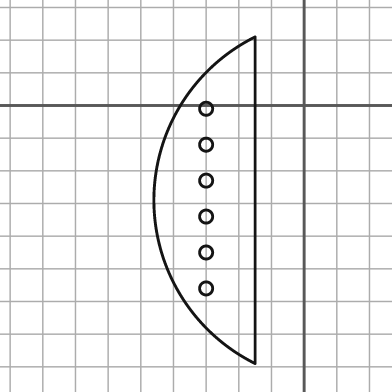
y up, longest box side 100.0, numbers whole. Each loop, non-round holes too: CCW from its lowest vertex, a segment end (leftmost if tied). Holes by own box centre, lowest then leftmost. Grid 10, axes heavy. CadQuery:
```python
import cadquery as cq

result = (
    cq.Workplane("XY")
    .moveTo(-15.0, -79.0)
    .lineTo(-15.0, 21.0)
    .threePointArc((-46.0, -29.0), (-15.0, -79.0))
    .close()
    .moveTo(-30.0, -56.0)
    .circle(2.0)
    .moveTo(-30.0, -45.0)
    .circle(2.0)
    .moveTo(-30.0, -34.0)
    .circle(2.0)
    .moveTo(-30.0, -23.0)
    .circle(2.0)
    .moveTo(-30.0, -12.0)
    .circle(2.0)
    .moveTo(-30.0, -1.0)
    .circle(2.0)
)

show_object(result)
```